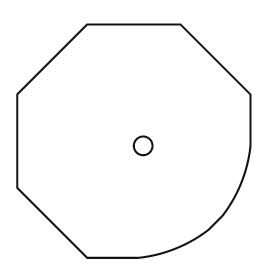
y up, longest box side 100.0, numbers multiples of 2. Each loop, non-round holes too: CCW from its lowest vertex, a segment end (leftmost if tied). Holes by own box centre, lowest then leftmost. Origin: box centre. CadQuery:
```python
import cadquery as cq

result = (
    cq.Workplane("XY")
    .moveTo(-20.0, -50.0)
    .lineTo(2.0, -50.0)
    .threePointArc((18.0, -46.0), (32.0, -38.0))
    .lineTo(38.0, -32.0)
    .threePointArc((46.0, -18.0), (50.0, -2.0))
    .lineTo(50.0, 20.0)
    .lineTo(20.0, 50.0)
    .lineTo(-20.0, 50.0)
    .lineTo(-50.0, 20.0)
    .lineTo(-50.0, -20.0)
    .close()
    .moveTo(4.0, -2.0)
    .circle(4.0)
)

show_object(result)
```